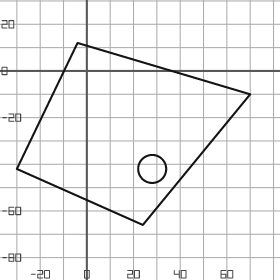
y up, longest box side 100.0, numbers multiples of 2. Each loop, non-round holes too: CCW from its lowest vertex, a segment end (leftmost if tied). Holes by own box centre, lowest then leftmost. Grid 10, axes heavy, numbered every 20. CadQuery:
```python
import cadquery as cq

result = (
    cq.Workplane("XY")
    .moveTo(24.0, -66.0)
    .lineTo(70.0, -10.0)
    .lineTo(-4.0, 12.0)
    .lineTo(-30.0, -42.0)
    .close()
    .moveTo(28.0, -42.0)
    .circle(6.0)
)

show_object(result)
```